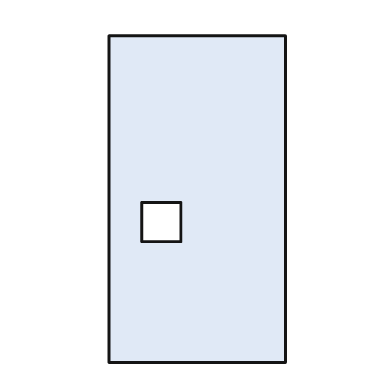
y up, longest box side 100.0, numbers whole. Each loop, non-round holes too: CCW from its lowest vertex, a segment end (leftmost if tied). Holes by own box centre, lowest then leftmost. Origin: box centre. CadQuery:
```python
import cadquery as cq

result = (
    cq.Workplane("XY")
    .moveTo(-27.0, -50.0)
    .lineTo(27.0, -50.0)
    .lineTo(27.0, 50.0)
    .lineTo(-27.0, 50.0)
    .close()
    .moveTo(-17.0, -13.0)
    .lineTo(-5.0, -13.0)
    .lineTo(-5.0, -1.0)
    .lineTo(-17.0, -1.0)
    .close()
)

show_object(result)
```